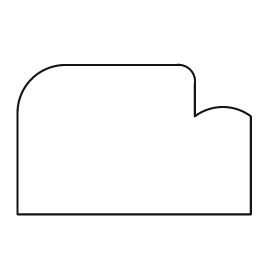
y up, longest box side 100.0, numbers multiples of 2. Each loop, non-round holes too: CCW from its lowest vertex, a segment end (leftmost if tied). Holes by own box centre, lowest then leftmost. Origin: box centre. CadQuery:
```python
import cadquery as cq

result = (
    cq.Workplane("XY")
    .moveTo(-50.0, -32.0)
    .lineTo(50.0, -32.0)
    .lineTo(50.0, 10.0)
    .threePointArc((38.0, 14.0), (26.0, 10.0))
    .lineTo(26.0, 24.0)
    .threePointArc((24.0, 30.0), (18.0, 32.0))
    .lineTo(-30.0, 32.0)
    .threePointArc((-44.0, 26.0), (-50.0, 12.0))
    .close()
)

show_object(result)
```